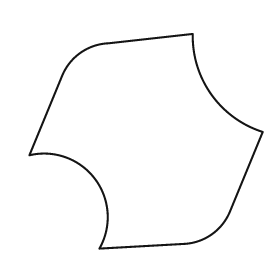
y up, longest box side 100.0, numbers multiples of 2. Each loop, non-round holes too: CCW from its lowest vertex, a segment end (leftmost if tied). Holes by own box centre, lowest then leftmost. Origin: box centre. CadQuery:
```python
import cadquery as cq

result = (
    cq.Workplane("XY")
    .moveTo(-20.0, -46.0)
    .lineTo(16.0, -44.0)
    .threePointArc((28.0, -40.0), (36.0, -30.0))
    .lineTo(50.0, 4.0)
    .threePointArc((28.0, 20.0), (20.0, 46.0))
    .lineTo(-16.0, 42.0)
    .threePointArc((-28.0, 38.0), (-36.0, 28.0))
    .lineTo(-50.0, -6.0)
    .threePointArc((-22.0, -16.0), (-20.0, -46.0))
    .close()
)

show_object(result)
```